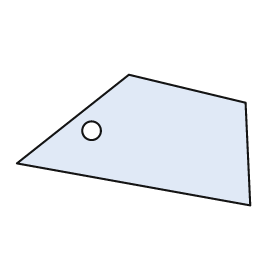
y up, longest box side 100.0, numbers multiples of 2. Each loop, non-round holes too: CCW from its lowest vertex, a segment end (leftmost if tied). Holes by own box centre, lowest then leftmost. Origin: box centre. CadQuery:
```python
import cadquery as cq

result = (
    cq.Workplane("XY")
    .moveTo(50.0, -28.0)
    .lineTo(48.0, 16.0)
    .lineTo(-2.0, 28.0)
    .lineTo(-50.0, -10.0)
    .close()
    .moveTo(-18.0, 4.0)
    .circle(4.0)
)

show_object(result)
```